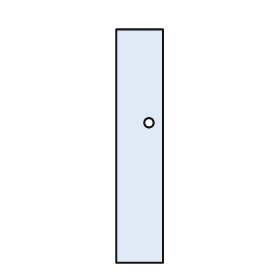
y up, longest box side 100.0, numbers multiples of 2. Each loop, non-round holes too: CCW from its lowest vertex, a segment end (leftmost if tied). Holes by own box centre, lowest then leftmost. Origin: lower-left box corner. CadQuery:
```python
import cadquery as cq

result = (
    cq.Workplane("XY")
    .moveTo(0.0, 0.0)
    .lineTo(20.0, 0.0)
    .lineTo(20.0, 100.0)
    .lineTo(0.0, 100.0)
    .close()
    .moveTo(14.0, 60.0)
    .circle(2.0)
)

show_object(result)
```